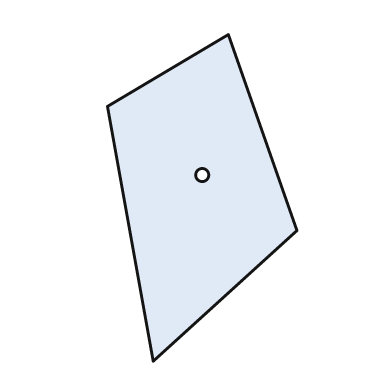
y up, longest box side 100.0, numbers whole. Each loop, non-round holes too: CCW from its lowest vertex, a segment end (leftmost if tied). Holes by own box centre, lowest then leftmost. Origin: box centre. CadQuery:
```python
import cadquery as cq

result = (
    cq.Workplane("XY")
    .moveTo(-15.0, -50.0)
    .lineTo(29.0, -10.0)
    .lineTo(8.0, 50.0)
    .lineTo(-29.0, 28.0)
    .close()
    .moveTo(0.0, 7.0)
    .circle(2.0)
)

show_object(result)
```